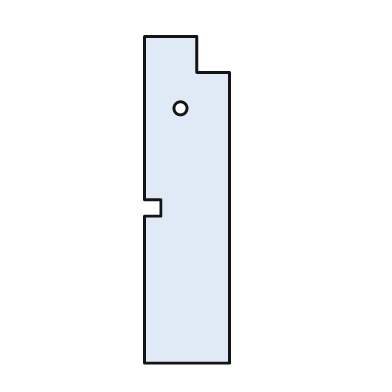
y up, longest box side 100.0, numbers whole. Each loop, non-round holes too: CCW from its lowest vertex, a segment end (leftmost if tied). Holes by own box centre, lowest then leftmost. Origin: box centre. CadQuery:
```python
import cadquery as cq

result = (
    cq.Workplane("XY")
    .moveTo(-13.0, -50.0)
    .lineTo(13.0, -50.0)
    .lineTo(13.0, 39.0)
    .lineTo(3.0, 39.0)
    .lineTo(3.0, 50.0)
    .lineTo(-13.0, 50.0)
    .lineTo(-13.0, 0.0)
    .lineTo(-8.0, 0.0)
    .lineTo(-8.0, -5.0)
    .lineTo(-13.0, -5.0)
    .close()
    .moveTo(-2.0, 28.0)
    .circle(2.0)
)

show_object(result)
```